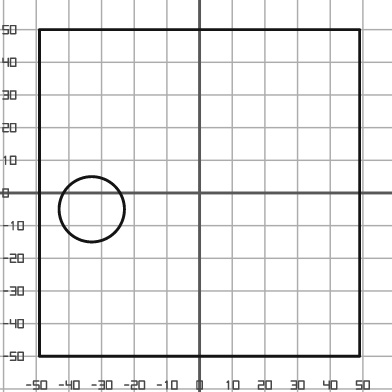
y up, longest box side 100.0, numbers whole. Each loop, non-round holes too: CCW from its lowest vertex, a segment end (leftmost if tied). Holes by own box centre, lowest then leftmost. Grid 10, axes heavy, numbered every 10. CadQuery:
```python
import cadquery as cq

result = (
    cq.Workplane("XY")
    .moveTo(-49.0, -50.0)
    .lineTo(49.0, -50.0)
    .lineTo(49.0, 50.0)
    .lineTo(-49.0, 50.0)
    .close()
    .moveTo(-33.0, -5.0)
    .circle(10.0)
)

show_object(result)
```